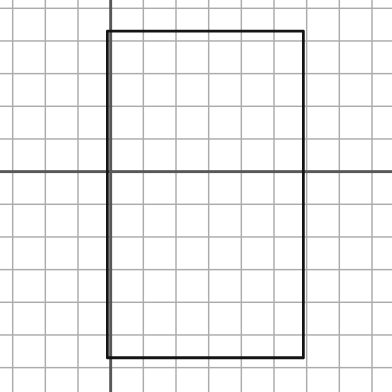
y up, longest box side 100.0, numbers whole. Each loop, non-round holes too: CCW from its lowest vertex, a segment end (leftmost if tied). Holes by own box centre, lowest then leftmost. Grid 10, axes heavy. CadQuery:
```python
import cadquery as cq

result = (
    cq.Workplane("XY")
    .moveTo(-1.0, -57.0)
    .lineTo(59.0, -57.0)
    .lineTo(59.0, 43.0)
    .lineTo(-1.0, 43.0)
    .close()
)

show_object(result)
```